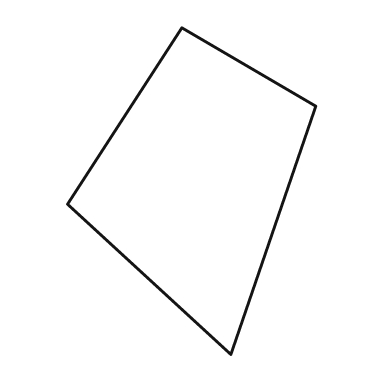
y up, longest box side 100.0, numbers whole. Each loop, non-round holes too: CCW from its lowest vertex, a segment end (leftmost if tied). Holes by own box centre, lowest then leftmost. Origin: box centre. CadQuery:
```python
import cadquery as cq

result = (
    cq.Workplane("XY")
    .moveTo(12.0, -50.0)
    .lineTo(38.0, 26.0)
    .lineTo(-3.0, 50.0)
    .lineTo(-38.0, -4.0)
    .close()
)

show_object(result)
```